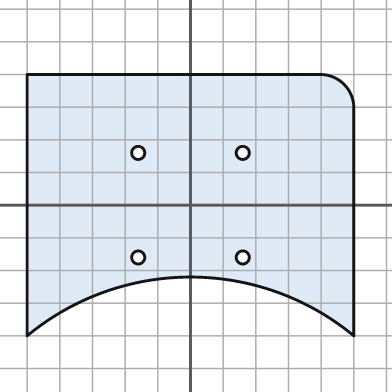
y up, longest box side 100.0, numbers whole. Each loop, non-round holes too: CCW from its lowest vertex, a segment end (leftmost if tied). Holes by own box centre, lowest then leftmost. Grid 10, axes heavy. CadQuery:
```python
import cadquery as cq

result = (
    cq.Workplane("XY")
    .moveTo(-50.0, -40.0)
    .threePointArc((0.0, -22.0), (50.0, -40.0))
    .lineTo(50.0, 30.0)
    .threePointArc((47.0, 37.0), (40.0, 40.0))
    .lineTo(-50.0, 40.0)
    .close()
    .moveTo(-16.0, -16.0)
    .circle(2.0)
    .moveTo(16.0, -16.0)
    .circle(2.0)
    .moveTo(-16.0, 16.0)
    .circle(2.0)
    .moveTo(16.0, 16.0)
    .circle(2.0)
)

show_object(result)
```